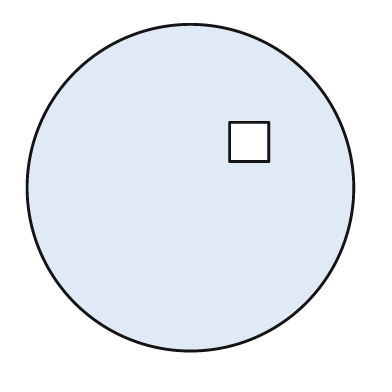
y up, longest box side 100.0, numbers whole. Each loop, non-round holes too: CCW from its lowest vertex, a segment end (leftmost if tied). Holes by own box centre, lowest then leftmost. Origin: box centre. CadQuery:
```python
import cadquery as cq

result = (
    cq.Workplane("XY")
    .moveTo(0.0, 0.0)
    .circle(50.0)
    .moveTo(12.0, 8.0)
    .lineTo(24.0, 8.0)
    .lineTo(24.0, 20.0)
    .lineTo(12.0, 20.0)
    .close()
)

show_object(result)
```